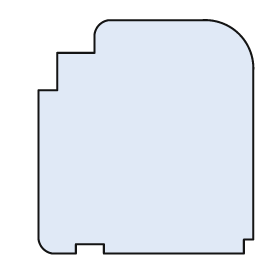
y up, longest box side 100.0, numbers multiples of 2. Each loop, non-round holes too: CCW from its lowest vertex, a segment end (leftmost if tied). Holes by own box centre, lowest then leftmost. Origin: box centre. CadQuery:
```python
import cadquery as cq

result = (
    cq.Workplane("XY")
    .moveTo(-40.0, -50.0)
    .lineTo(-30.0, -50.0)
    .lineTo(-30.0, -46.0)
    .lineTo(-18.0, -46.0)
    .lineTo(-18.0, -50.0)
    .lineTo(42.0, -50.0)
    .lineTo(42.0, -44.0)
    .lineTo(46.0, -44.0)
    .lineTo(46.0, 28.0)
    .threePointArc((40.0, 44.0), (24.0, 50.0))
    .lineTo(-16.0, 50.0)
    .threePointArc((-20.0, 48.0), (-22.0, 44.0))
    .lineTo(-22.0, 36.0)
    .lineTo(-38.0, 36.0)
    .lineTo(-38.0, 20.0)
    .lineTo(-46.0, 20.0)
    .lineTo(-46.0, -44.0)
    .threePointArc((-44.0, -48.0), (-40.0, -50.0))
    .close()
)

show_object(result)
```